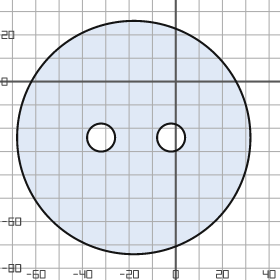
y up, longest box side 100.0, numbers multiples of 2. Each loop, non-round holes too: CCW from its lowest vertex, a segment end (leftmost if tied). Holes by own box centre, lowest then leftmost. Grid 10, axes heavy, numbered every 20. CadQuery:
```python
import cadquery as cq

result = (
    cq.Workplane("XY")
    .moveTo(-18.0, -24.0)
    .circle(50.0)
    .moveTo(-32.0, -24.0)
    .circle(6.0)
    .moveTo(-2.0, -24.0)
    .circle(6.0)
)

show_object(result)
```